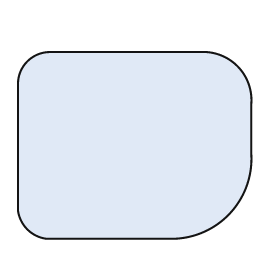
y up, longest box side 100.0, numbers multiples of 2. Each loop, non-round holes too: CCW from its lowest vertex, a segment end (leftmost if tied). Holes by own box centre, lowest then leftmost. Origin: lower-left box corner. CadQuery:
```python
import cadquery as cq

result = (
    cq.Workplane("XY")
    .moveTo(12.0, 0.0)
    .lineTo(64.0, 0.0)
    .threePointArc((90.0, 10.0), (100.0, 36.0))
    .lineTo(100.0, 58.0)
    .threePointArc((94.0, 74.0), (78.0, 80.0))
    .lineTo(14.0, 80.0)
    .threePointArc((4.0, 76.0), (0.0, 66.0))
    .lineTo(0.0, 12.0)
    .threePointArc((4.0, 4.0), (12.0, 0.0))
    .close()
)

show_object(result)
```